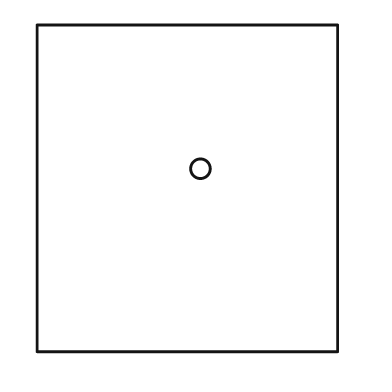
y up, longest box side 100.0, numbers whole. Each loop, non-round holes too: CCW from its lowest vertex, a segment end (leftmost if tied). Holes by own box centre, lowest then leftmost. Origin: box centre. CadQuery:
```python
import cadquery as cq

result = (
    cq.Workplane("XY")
    .moveTo(-46.0, -50.0)
    .lineTo(46.0, -50.0)
    .lineTo(46.0, 50.0)
    .lineTo(-46.0, 50.0)
    .close()
    .moveTo(4.0, 6.0)
    .circle(3.0)
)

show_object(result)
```